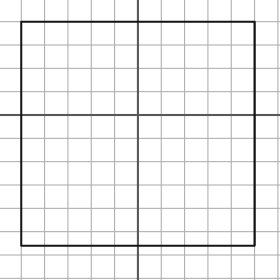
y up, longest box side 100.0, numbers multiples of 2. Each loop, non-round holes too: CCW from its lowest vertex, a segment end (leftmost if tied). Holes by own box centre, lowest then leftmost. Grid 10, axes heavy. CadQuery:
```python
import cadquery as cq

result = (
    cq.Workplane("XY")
    .moveTo(-50.0, -56.0)
    .lineTo(50.0, -56.0)
    .lineTo(50.0, 40.0)
    .lineTo(-50.0, 40.0)
    .close()
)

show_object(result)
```